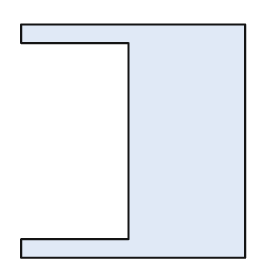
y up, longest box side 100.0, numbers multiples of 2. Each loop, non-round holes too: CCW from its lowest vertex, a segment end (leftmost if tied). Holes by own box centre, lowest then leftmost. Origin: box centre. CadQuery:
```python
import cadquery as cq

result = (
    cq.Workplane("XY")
    .moveTo(-48.0, -50.0)
    .lineTo(48.0, -50.0)
    .lineTo(48.0, 50.0)
    .lineTo(-48.0, 50.0)
    .lineTo(-48.0, 42.0)
    .lineTo(-2.0, 42.0)
    .lineTo(-2.0, -42.0)
    .lineTo(-48.0, -42.0)
    .close()
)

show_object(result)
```